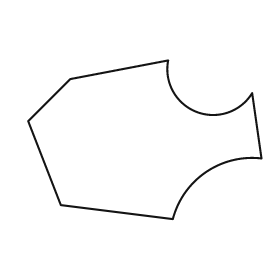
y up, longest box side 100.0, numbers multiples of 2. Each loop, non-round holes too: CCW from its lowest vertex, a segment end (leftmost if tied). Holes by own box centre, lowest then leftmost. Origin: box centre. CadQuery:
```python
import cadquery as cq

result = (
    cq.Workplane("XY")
    .moveTo(12.0, -34.0)
    .threePointArc((26.0, -14.0), (50.0, -8.0))
    .lineTo(46.0, 20.0)
    .threePointArc((22.0, 12.0), (10.0, 34.0))
    .lineTo(-32.0, 26.0)
    .lineTo(-50.0, 8.0)
    .lineTo(-36.0, -28.0)
    .close()
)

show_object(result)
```